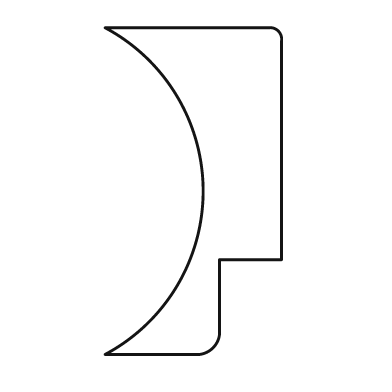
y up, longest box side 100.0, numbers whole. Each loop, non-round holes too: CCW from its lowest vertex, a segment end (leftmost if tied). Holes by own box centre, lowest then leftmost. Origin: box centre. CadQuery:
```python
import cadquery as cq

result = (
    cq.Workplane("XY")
    .moveTo(-27.0, -50.0)
    .lineTo(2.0, -50.0)
    .threePointArc((6.0, -48.0), (8.0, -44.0))
    .lineTo(8.0, -21.0)
    .lineTo(27.0, -21.0)
    .lineTo(27.0, 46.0)
    .threePointArc((26.0, 49.0), (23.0, 50.0))
    .lineTo(-27.0, 50.0)
    .threePointArc((3.0, 0.0), (-27.0, -50.0))
    .close()
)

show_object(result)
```